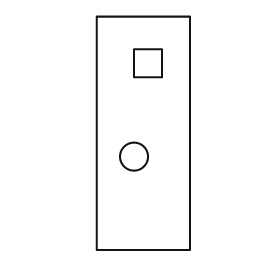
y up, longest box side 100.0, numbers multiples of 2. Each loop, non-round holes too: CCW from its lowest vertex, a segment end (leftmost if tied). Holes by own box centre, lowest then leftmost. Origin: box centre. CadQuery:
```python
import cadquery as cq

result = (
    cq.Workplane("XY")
    .moveTo(-20.0, -50.0)
    .lineTo(20.0, -50.0)
    .lineTo(20.0, 50.0)
    .lineTo(-20.0, 50.0)
    .close()
    .moveTo(-4.0, -10.0)
    .circle(6.0)
    .moveTo(-4.0, 24.0)
    .lineTo(8.0, 24.0)
    .lineTo(8.0, 36.0)
    .lineTo(-4.0, 36.0)
    .close()
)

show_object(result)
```